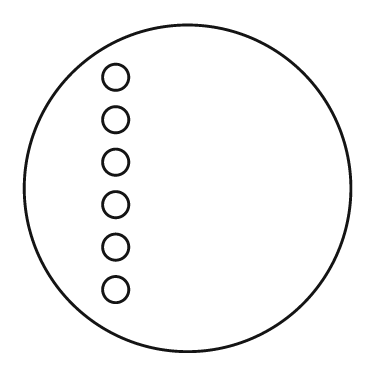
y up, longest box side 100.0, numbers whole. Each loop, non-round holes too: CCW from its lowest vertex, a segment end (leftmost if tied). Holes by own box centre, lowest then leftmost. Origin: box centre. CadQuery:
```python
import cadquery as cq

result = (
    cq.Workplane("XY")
    .moveTo(0.0, 0.0)
    .circle(50.0)
    .moveTo(-22.0, -31.0)
    .circle(4.0)
    .moveTo(-22.0, -18.0)
    .circle(4.0)
    .moveTo(-22.0, -5.0)
    .circle(4.0)
    .moveTo(-22.0, 8.0)
    .circle(4.0)
    .moveTo(-22.0, 21.0)
    .circle(4.0)
    .moveTo(-22.0, 34.0)
    .circle(4.0)
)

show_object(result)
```